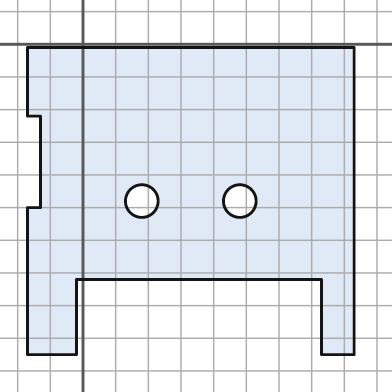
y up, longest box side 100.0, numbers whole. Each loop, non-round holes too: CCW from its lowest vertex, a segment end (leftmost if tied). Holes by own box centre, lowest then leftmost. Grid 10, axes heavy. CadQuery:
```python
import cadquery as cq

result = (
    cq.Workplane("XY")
    .moveTo(-17.0, -95.0)
    .lineTo(-2.0, -95.0)
    .lineTo(-2.0, -72.0)
    .lineTo(73.0, -72.0)
    .lineTo(73.0, -95.0)
    .lineTo(83.0, -95.0)
    .lineTo(83.0, -1.0)
    .lineTo(-17.0, -1.0)
    .lineTo(-17.0, -22.0)
    .lineTo(-13.0, -22.0)
    .lineTo(-13.0, -50.0)
    .lineTo(-17.0, -50.0)
    .close()
    .moveTo(18.0, -48.0)
    .circle(5.0)
    .moveTo(48.0, -48.0)
    .circle(5.0)
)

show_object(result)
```